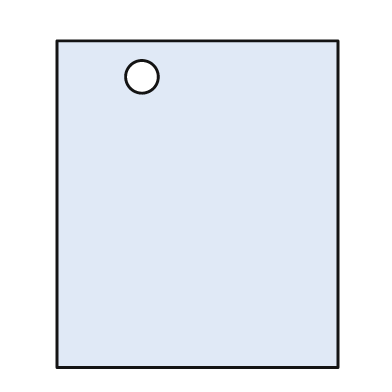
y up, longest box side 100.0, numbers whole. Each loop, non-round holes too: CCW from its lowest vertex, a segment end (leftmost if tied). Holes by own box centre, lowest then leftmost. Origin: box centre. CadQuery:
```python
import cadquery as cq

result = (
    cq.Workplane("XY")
    .moveTo(-43.0, -50.0)
    .lineTo(43.0, -50.0)
    .lineTo(43.0, 50.0)
    .lineTo(-43.0, 50.0)
    .close()
    .moveTo(-17.0, 39.0)
    .circle(5.0)
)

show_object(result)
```